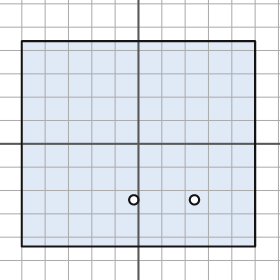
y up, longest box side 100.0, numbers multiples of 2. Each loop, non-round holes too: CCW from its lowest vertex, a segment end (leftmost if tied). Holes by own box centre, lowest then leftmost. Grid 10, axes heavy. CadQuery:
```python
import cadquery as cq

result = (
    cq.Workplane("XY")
    .moveTo(-50.0, -44.0)
    .lineTo(50.0, -44.0)
    .lineTo(50.0, 44.0)
    .lineTo(-50.0, 44.0)
    .close()
    .moveTo(-2.0, -24.0)
    .circle(2.0)
    .moveTo(24.0, -24.0)
    .circle(2.0)
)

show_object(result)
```